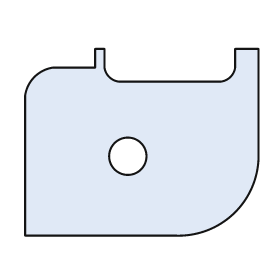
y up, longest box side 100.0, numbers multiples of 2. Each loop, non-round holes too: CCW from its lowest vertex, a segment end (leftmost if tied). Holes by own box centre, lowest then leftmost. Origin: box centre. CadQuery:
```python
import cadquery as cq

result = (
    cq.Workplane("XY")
    .moveTo(-50.0, -40.0)
    .lineTo(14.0, -40.0)
    .threePointArc((40.0, -30.0), (50.0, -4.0))
    .lineTo(50.0, 40.0)
    .lineTo(40.0, 40.0)
    .lineTo(40.0, 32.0)
    .threePointArc((38.0, 28.0), (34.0, 26.0))
    .lineTo(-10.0, 26.0)
    .threePointArc((-14.0, 28.0), (-16.0, 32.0))
    .lineTo(-16.0, 40.0)
    .lineTo(-20.0, 40.0)
    .lineTo(-20.0, 32.0)
    .lineTo(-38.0, 32.0)
    .threePointArc((-46.0, 28.0), (-50.0, 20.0))
    .close()
    .moveTo(-6.0, -6.0)
    .circle(8.0)
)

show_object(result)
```